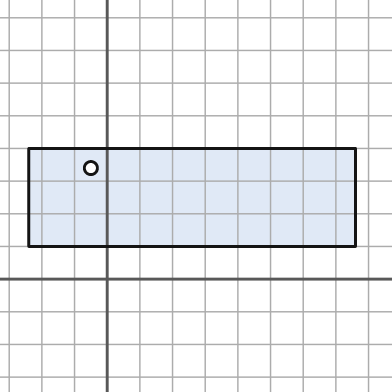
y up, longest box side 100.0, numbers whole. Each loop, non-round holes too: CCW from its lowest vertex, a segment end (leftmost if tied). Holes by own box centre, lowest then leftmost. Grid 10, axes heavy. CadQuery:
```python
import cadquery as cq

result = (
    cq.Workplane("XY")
    .moveTo(-24.0, 10.0)
    .lineTo(76.0, 10.0)
    .lineTo(76.0, 40.0)
    .lineTo(-24.0, 40.0)
    .close()
    .moveTo(-5.0, 34.0)
    .circle(2.0)
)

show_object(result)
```